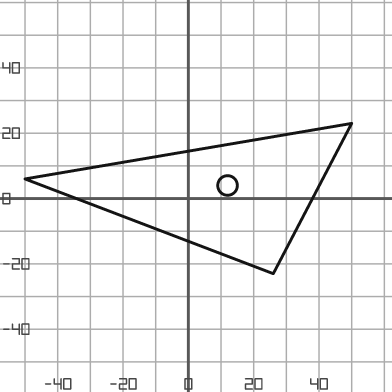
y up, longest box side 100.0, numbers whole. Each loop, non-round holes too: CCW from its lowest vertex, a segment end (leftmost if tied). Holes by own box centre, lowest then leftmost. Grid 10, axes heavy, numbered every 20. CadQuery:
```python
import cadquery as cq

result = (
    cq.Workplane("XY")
    .moveTo(26.0, -23.0)
    .lineTo(50.0, 23.0)
    .lineTo(-50.0, 6.0)
    .close()
    .moveTo(12.0, 4.0)
    .circle(3.0)
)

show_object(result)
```